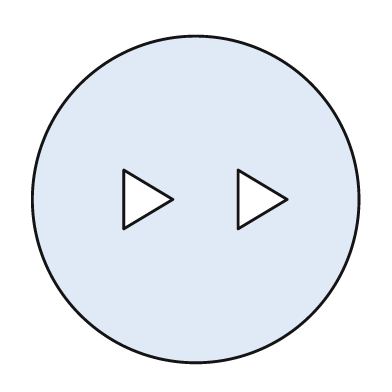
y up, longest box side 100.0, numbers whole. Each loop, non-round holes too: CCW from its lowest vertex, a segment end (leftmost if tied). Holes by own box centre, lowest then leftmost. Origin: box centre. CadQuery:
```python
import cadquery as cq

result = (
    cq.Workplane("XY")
    .moveTo(0.0, 0.0)
    .circle(50.0)
    .moveTo(-22.0, -9.0)
    .lineTo(-7.0, 0.0)
    .lineTo(-22.0, 9.0)
    .close()
    .moveTo(13.0, -9.0)
    .lineTo(28.0, 0.0)
    .lineTo(13.0, 9.0)
    .close()
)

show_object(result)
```